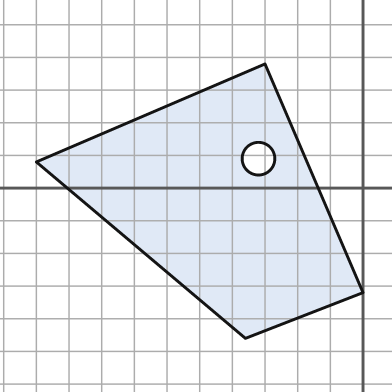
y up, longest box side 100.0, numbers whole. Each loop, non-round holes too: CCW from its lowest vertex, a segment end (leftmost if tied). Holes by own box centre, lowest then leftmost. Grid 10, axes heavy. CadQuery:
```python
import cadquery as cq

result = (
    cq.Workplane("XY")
    .moveTo(-36.0, -46.0)
    .lineTo(0.0, -32.0)
    .lineTo(-30.0, 38.0)
    .lineTo(-100.0, 8.0)
    .close()
    .moveTo(-32.0, 9.0)
    .circle(5.0)
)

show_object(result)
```